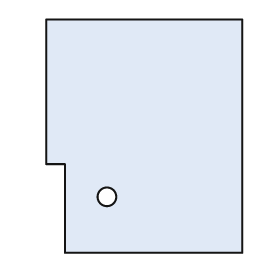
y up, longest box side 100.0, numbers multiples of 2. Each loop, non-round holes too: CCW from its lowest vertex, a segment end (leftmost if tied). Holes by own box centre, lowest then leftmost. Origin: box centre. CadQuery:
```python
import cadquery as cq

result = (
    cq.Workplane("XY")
    .moveTo(-34.0, -50.0)
    .lineTo(42.0, -50.0)
    .lineTo(42.0, 50.0)
    .lineTo(-42.0, 50.0)
    .lineTo(-42.0, -12.0)
    .lineTo(-34.0, -12.0)
    .close()
    .moveTo(-16.0, -26.0)
    .circle(4.0)
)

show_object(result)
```